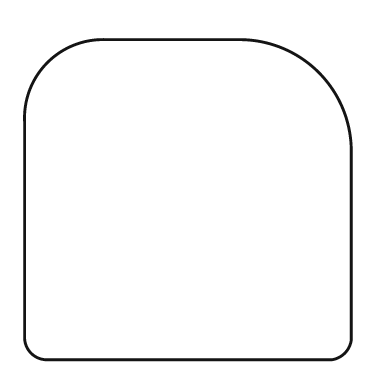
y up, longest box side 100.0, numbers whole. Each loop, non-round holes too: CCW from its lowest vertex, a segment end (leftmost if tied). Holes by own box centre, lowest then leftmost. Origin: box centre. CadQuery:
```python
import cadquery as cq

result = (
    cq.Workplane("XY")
    .moveTo(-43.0, -49.0)
    .lineTo(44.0, -49.0)
    .threePointArc((48.0, -47.0), (50.0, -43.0))
    .lineTo(50.0, 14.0)
    .threePointArc((40.0, 39.0), (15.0, 49.0))
    .lineTo(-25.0, 49.0)
    .threePointArc((-43.0, 42.0), (-50.0, 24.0))
    .lineTo(-50.0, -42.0)
    .threePointArc((-48.0, -47.0), (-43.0, -49.0))
    .close()
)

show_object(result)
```